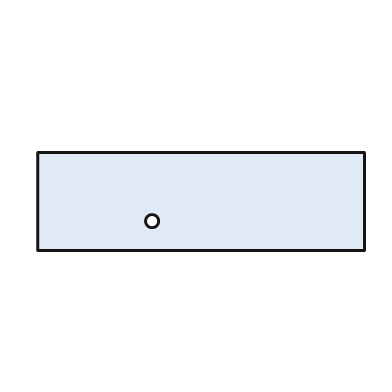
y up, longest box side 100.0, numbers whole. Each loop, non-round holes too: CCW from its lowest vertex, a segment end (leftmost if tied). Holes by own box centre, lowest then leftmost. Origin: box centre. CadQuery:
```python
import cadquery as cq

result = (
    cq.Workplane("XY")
    .moveTo(-50.0, -15.0)
    .lineTo(50.0, -15.0)
    .lineTo(50.0, 15.0)
    .lineTo(-50.0, 15.0)
    .close()
    .moveTo(-15.0, -6.0)
    .circle(2.0)
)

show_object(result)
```